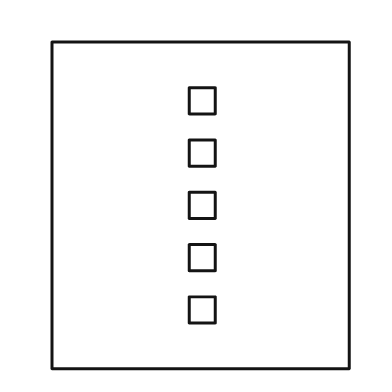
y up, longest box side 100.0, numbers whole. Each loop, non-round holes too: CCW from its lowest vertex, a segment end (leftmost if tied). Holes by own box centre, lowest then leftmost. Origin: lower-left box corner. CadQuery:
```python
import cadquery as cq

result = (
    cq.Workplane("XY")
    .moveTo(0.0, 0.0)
    .lineTo(91.0, 0.0)
    .lineTo(91.0, 100.0)
    .lineTo(0.0, 100.0)
    .close()
    .moveTo(42.0, 14.0)
    .lineTo(50.0, 14.0)
    .lineTo(50.0, 22.0)
    .lineTo(42.0, 22.0)
    .close()
    .moveTo(42.0, 30.0)
    .lineTo(50.0, 30.0)
    .lineTo(50.0, 38.0)
    .lineTo(42.0, 38.0)
    .close()
    .moveTo(42.0, 46.0)
    .lineTo(50.0, 46.0)
    .lineTo(50.0, 54.0)
    .lineTo(42.0, 54.0)
    .close()
    .moveTo(42.0, 62.0)
    .lineTo(50.0, 62.0)
    .lineTo(50.0, 70.0)
    .lineTo(42.0, 70.0)
    .close()
    .moveTo(42.0, 78.0)
    .lineTo(50.0, 78.0)
    .lineTo(50.0, 86.0)
    .lineTo(42.0, 86.0)
    .close()
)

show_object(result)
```